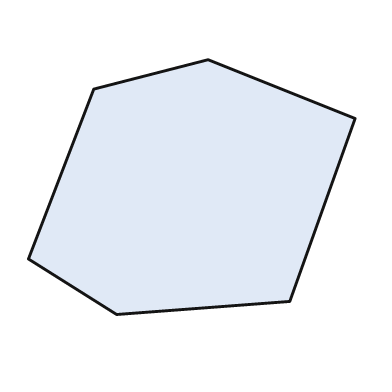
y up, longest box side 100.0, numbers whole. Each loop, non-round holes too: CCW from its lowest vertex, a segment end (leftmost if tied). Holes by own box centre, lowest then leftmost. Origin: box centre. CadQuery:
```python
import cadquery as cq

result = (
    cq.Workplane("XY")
    .moveTo(-23.0, -39.0)
    .lineTo(30.0, -35.0)
    .lineTo(50.0, 21.0)
    .lineTo(5.0, 39.0)
    .lineTo(-30.0, 30.0)
    .lineTo(-50.0, -22.0)
    .close()
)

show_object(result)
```